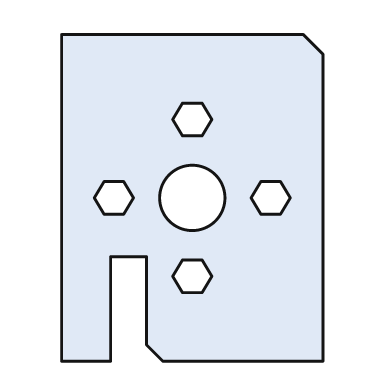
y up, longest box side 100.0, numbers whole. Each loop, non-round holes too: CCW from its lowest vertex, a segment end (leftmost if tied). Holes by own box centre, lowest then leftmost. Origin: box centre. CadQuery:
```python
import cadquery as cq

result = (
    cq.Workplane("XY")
    .moveTo(-40.0, -50.0)
    .lineTo(-25.0, -50.0)
    .lineTo(-25.0, -18.0)
    .lineTo(-14.0, -18.0)
    .lineTo(-14.0, -45.0)
    .lineTo(-9.0, -50.0)
    .lineTo(40.0, -50.0)
    .lineTo(40.0, 44.0)
    .lineTo(34.0, 50.0)
    .lineTo(-40.0, 50.0)
    .close()
    .moveTo(-3.0, -29.0)
    .lineTo(3.0, -29.0)
    .lineTo(6.0, -24.0)
    .lineTo(3.0, -19.0)
    .lineTo(-3.0, -19.0)
    .lineTo(-6.0, -24.0)
    .close()
    .moveTo(-27.0, -5.0)
    .lineTo(-21.0, -5.0)
    .lineTo(-18.0, 0.0)
    .lineTo(-21.0, 5.0)
    .lineTo(-27.0, 5.0)
    .lineTo(-30.0, 0.0)
    .close()
    .moveTo(0.0, 0.0)
    .circle(10.0)
    .moveTo(21.0, -5.0)
    .lineTo(27.0, -5.0)
    .lineTo(30.0, 0.0)
    .lineTo(27.0, 5.0)
    .lineTo(21.0, 5.0)
    .lineTo(18.0, 0.0)
    .close()
    .moveTo(-3.0, 19.0)
    .lineTo(3.0, 19.0)
    .lineTo(6.0, 24.0)
    .lineTo(3.0, 29.0)
    .lineTo(-3.0, 29.0)
    .lineTo(-6.0, 24.0)
    .close()
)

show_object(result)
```